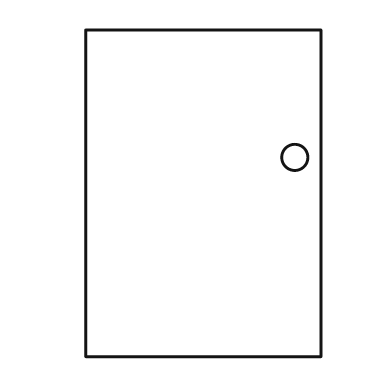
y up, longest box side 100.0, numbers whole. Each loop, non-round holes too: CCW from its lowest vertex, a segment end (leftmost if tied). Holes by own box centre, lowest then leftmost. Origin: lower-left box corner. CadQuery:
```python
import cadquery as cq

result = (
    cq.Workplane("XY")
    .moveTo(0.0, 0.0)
    .lineTo(72.0, 0.0)
    .lineTo(72.0, 100.0)
    .lineTo(0.0, 100.0)
    .close()
    .moveTo(64.0, 61.0)
    .circle(4.0)
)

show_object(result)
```